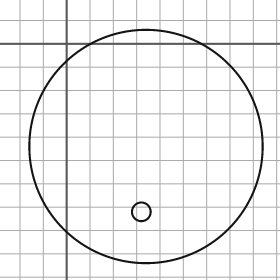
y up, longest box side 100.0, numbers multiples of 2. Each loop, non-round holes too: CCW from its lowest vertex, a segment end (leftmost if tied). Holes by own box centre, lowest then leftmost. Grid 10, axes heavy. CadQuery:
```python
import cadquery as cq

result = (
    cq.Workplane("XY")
    .moveTo(34.0, -44.0)
    .circle(50.0)
    .moveTo(32.0, -72.0)
    .circle(4.0)
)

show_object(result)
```